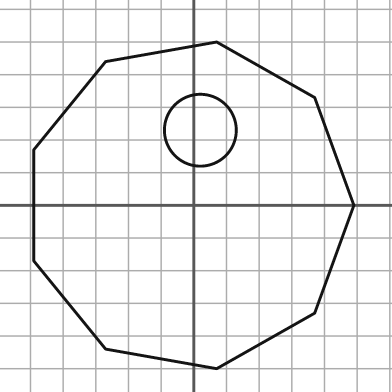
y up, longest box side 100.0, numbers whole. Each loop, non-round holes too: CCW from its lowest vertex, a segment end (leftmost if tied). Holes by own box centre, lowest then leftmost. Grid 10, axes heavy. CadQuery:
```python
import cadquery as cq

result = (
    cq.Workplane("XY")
    .moveTo(7.0, -50.0)
    .lineTo(37.0, -33.0)
    .lineTo(49.0, 0.0)
    .lineTo(37.0, 33.0)
    .lineTo(7.0, 50.0)
    .lineTo(-27.0, 44.0)
    .lineTo(-49.0, 17.0)
    .lineTo(-49.0, -17.0)
    .lineTo(-27.0, -44.0)
    .close()
    .moveTo(2.0, 23.0)
    .circle(11.0)
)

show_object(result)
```